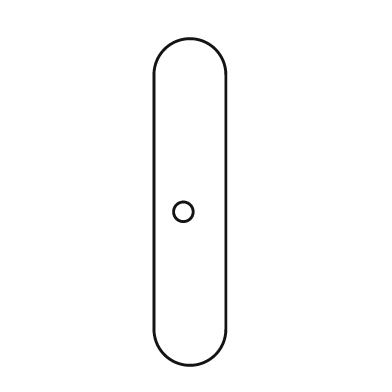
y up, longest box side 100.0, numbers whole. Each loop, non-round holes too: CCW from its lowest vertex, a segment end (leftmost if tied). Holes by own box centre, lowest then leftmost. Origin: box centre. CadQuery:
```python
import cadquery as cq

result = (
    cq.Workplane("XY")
    .moveTo(-11.0, -39.0)
    .threePointArc((0.0, -50.0), (11.0, -39.0))
    .lineTo(11.0, 39.0)
    .threePointArc((0.0, 50.0), (-11.0, 39.0))
    .close()
    .moveTo(-2.0, -3.0)
    .circle(3.0)
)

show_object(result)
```